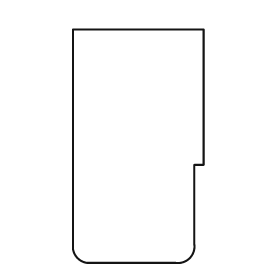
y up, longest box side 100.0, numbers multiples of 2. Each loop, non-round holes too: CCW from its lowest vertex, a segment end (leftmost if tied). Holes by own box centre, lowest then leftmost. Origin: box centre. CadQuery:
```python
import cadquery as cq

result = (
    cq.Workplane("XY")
    .moveTo(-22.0, -50.0)
    .lineTo(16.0, -50.0)
    .threePointArc((22.0, -48.0), (24.0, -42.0))
    .lineTo(24.0, -8.0)
    .lineTo(28.0, -8.0)
    .lineTo(28.0, 50.0)
    .lineTo(-28.0, 50.0)
    .lineTo(-28.0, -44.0)
    .threePointArc((-26.0, -48.0), (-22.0, -50.0))
    .close()
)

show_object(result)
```